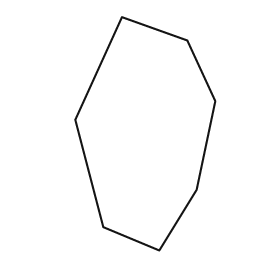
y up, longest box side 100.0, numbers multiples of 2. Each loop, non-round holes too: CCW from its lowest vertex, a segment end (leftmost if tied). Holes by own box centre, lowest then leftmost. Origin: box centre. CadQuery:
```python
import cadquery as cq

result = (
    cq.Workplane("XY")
    .moveTo(6.0, -50.0)
    .lineTo(22.0, -24.0)
    .lineTo(30.0, 14.0)
    .lineTo(18.0, 40.0)
    .lineTo(-10.0, 50.0)
    .lineTo(-30.0, 6.0)
    .lineTo(-18.0, -40.0)
    .close()
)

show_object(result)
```